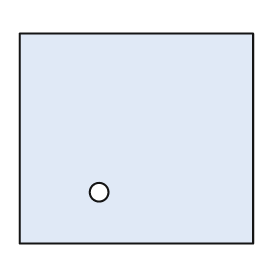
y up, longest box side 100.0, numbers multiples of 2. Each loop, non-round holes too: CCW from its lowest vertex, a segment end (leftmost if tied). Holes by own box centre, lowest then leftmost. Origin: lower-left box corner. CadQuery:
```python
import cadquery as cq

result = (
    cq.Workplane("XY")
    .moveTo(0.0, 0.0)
    .lineTo(100.0, 0.0)
    .lineTo(100.0, 90.0)
    .lineTo(0.0, 90.0)
    .close()
    .moveTo(34.0, 22.0)
    .circle(4.0)
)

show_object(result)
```